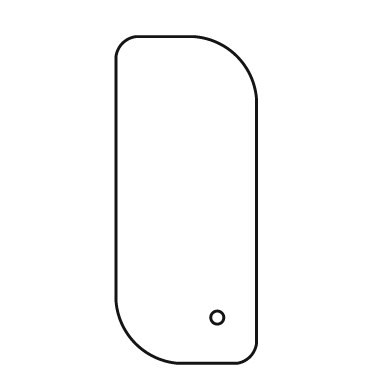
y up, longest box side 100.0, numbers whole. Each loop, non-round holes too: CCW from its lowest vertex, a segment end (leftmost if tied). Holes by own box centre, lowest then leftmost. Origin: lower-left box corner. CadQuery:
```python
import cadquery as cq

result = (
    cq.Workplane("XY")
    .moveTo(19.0, 0.0)
    .lineTo(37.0, 0.0)
    .threePointArc((41.0, 2.0), (43.0, 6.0))
    .lineTo(43.0, 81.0)
    .threePointArc((37.0, 94.0), (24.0, 100.0))
    .lineTo(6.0, 100.0)
    .threePointArc((2.0, 98.0), (0.0, 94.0))
    .lineTo(0.0, 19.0)
    .threePointArc((6.0, 6.0), (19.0, 0.0))
    .close()
    .moveTo(31.0, 14.0)
    .circle(2.0)
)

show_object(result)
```